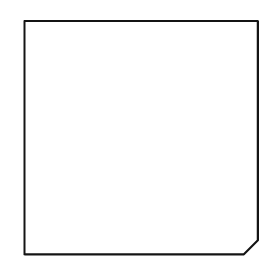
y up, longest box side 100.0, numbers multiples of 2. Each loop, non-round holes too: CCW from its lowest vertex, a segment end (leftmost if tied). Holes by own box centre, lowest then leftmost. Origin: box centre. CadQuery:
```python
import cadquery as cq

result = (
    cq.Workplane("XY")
    .moveTo(-50.0, -50.0)
    .lineTo(44.0, -50.0)
    .lineTo(50.0, -44.0)
    .lineTo(50.0, 50.0)
    .lineTo(-50.0, 50.0)
    .close()
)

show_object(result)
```